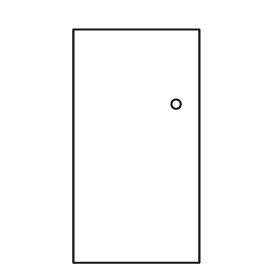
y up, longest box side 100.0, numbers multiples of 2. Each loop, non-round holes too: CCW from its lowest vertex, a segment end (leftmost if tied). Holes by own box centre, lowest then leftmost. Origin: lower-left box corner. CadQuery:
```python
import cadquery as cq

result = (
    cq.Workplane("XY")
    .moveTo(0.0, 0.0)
    .lineTo(54.0, 0.0)
    .lineTo(54.0, 100.0)
    .lineTo(0.0, 100.0)
    .close()
    .moveTo(44.0, 68.0)
    .circle(2.0)
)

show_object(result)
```